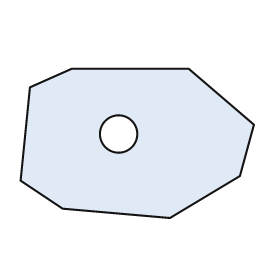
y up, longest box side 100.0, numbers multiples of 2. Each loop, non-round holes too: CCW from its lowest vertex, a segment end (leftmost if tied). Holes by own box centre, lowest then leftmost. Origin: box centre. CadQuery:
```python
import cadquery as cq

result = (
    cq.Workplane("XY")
    .moveTo(14.0, -32.0)
    .lineTo(44.0, -14.0)
    .lineTo(50.0, 8.0)
    .lineTo(22.0, 32.0)
    .lineTo(-28.0, 32.0)
    .lineTo(-46.0, 24.0)
    .lineTo(-50.0, -16.0)
    .lineTo(-32.0, -28.0)
    .close()
    .moveTo(-8.0, 4.0)
    .circle(8.0)
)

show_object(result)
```